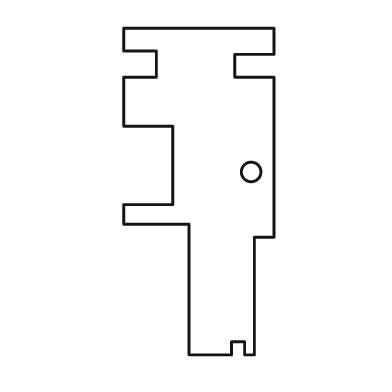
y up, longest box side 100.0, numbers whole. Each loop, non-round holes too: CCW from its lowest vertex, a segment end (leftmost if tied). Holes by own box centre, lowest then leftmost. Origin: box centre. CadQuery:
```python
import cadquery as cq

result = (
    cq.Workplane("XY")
    .moveTo(-3.0, -50.0)
    .lineTo(10.0, -50.0)
    .lineTo(10.0, -46.0)
    .lineTo(14.0, -46.0)
    .lineTo(14.0, -50.0)
    .lineTo(17.0, -50.0)
    .lineTo(17.0, -14.0)
    .lineTo(23.0, -14.0)
    .lineTo(23.0, 35.0)
    .lineTo(11.0, 35.0)
    .lineTo(11.0, 42.0)
    .lineTo(23.0, 42.0)
    .lineTo(23.0, 50.0)
    .lineTo(-23.0, 50.0)
    .lineTo(-23.0, 43.0)
    .lineTo(-13.0, 43.0)
    .lineTo(-13.0, 35.0)
    .lineTo(-23.0, 35.0)
    .lineTo(-23.0, 20.0)
    .lineTo(-8.0, 20.0)
    .lineTo(-8.0, -4.0)
    .lineTo(-23.0, -4.0)
    .lineTo(-23.0, -10.0)
    .lineTo(-3.0, -10.0)
    .close()
    .moveTo(16.0, 6.0)
    .circle(3.0)
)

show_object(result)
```